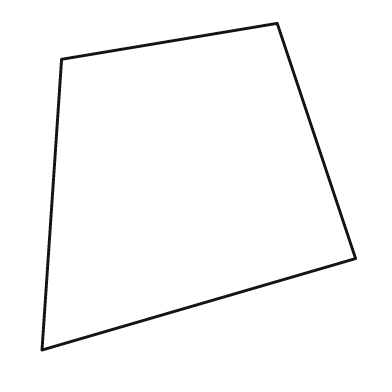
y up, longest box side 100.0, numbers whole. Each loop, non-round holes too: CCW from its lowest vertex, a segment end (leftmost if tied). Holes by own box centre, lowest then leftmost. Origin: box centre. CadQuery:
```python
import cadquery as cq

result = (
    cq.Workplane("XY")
    .moveTo(-48.0, -50.0)
    .lineTo(48.0, -22.0)
    .lineTo(24.0, 50.0)
    .lineTo(-42.0, 39.0)
    .close()
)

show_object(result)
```